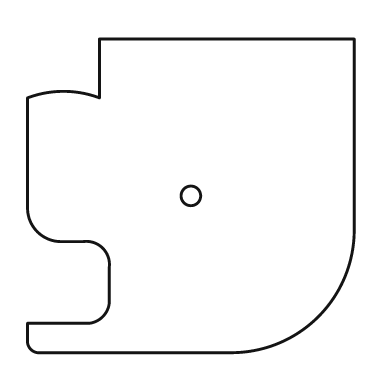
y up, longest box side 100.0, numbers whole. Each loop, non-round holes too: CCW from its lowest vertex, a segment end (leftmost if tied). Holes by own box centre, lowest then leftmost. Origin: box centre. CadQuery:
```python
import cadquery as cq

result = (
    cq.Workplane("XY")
    .moveTo(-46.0, -48.0)
    .lineTo(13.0, -48.0)
    .threePointArc((39.0, -37.0), (50.0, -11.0))
    .lineTo(50.0, 48.0)
    .lineTo(-28.0, 48.0)
    .lineTo(-28.0, 30.0)
    .threePointArc((-39.0, 32.0), (-50.0, 30.0))
    .lineTo(-50.0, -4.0)
    .threePointArc((-47.0, -11.0), (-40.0, -14.0))
    .lineTo(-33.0, -14.0)
    .threePointArc((-27.0, -16.0), (-25.0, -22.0))
    .lineTo(-25.0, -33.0)
    .threePointArc((-27.0, -37.0), (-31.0, -39.0))
    .lineTo(-50.0, -39.0)
    .lineTo(-50.0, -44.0)
    .threePointArc((-49.0, -47.0), (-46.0, -48.0))
    .close()
    .moveTo(0.0, 0.0)
    .circle(3.0)
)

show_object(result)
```